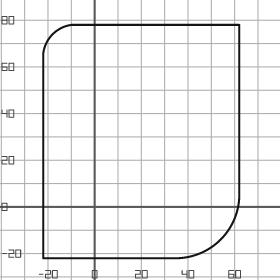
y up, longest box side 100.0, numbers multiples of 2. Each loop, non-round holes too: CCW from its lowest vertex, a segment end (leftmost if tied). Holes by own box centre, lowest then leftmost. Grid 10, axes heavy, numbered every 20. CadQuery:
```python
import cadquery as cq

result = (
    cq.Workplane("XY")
    .moveTo(-22.0, -22.0)
    .lineTo(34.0, -22.0)
    .threePointArc((54.0, -14.0), (62.0, 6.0))
    .lineTo(62.0, 78.0)
    .lineTo(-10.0, 78.0)
    .threePointArc((-18.0, 74.0), (-22.0, 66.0))
    .close()
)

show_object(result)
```